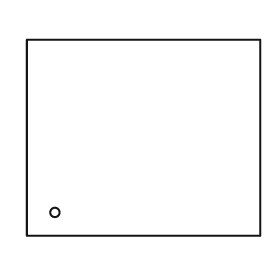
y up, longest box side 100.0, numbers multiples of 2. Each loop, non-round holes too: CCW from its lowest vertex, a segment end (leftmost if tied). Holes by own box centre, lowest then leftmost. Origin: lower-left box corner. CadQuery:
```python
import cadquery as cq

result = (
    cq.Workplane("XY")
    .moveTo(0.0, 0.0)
    .lineTo(100.0, 0.0)
    .lineTo(100.0, 84.0)
    .lineTo(0.0, 84.0)
    .close()
    .moveTo(12.0, 10.0)
    .circle(2.0)
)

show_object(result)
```